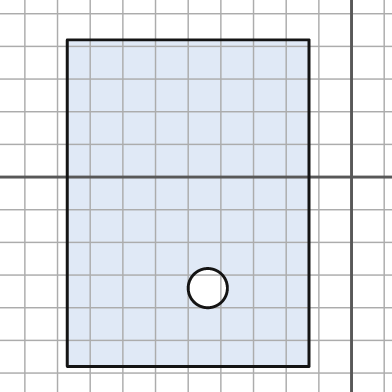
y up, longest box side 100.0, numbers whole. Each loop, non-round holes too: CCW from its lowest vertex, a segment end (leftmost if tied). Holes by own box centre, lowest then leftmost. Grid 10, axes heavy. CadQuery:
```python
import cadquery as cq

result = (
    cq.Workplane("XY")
    .moveTo(-87.0, -58.0)
    .lineTo(-13.0, -58.0)
    .lineTo(-13.0, 42.0)
    .lineTo(-87.0, 42.0)
    .close()
    .moveTo(-44.0, -34.0)
    .circle(6.0)
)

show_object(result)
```